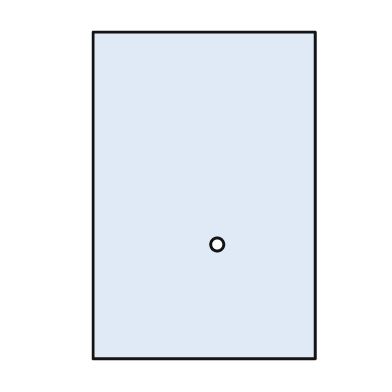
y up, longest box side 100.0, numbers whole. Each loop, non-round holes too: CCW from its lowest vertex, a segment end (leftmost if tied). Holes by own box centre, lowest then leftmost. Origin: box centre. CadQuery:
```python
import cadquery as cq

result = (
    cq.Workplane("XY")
    .moveTo(-34.0, -50.0)
    .lineTo(34.0, -50.0)
    .lineTo(34.0, 50.0)
    .lineTo(-34.0, 50.0)
    .close()
    .moveTo(4.0, -15.0)
    .circle(2.0)
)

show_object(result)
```